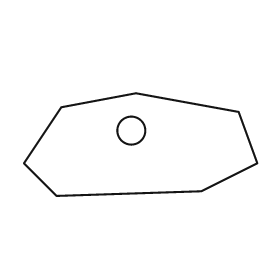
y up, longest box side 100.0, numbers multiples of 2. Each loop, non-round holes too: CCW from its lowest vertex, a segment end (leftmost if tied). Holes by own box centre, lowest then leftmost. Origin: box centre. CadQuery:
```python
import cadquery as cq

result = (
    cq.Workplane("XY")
    .moveTo(-36.0, -22.0)
    .lineTo(26.0, -20.0)
    .lineTo(50.0, -8.0)
    .lineTo(42.0, 14.0)
    .lineTo(-2.0, 22.0)
    .lineTo(-34.0, 16.0)
    .lineTo(-50.0, -8.0)
    .close()
    .moveTo(-4.0, 6.0)
    .circle(6.0)
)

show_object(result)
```